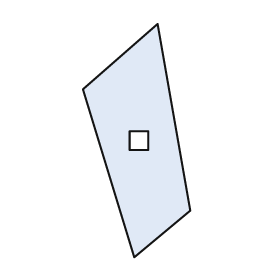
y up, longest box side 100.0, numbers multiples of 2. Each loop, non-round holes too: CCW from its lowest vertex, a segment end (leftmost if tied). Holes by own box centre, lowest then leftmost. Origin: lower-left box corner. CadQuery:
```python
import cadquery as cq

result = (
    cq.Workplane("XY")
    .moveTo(22.0, 0.0)
    .lineTo(46.0, 20.0)
    .lineTo(32.0, 100.0)
    .lineTo(0.0, 72.0)
    .close()
    .moveTo(20.0, 46.0)
    .lineTo(28.0, 46.0)
    .lineTo(28.0, 54.0)
    .lineTo(20.0, 54.0)
    .close()
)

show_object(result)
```